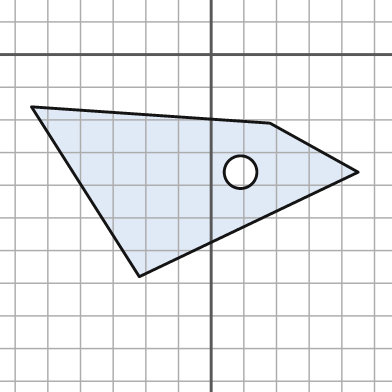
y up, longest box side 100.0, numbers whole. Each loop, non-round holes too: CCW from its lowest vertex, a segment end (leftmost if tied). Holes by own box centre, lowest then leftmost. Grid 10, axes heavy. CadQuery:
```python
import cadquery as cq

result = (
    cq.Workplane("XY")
    .moveTo(-22.0, -68.0)
    .lineTo(45.0, -36.0)
    .lineTo(18.0, -21.0)
    .lineTo(-55.0, -16.0)
    .close()
    .moveTo(9.0, -36.0)
    .circle(5.0)
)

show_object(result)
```